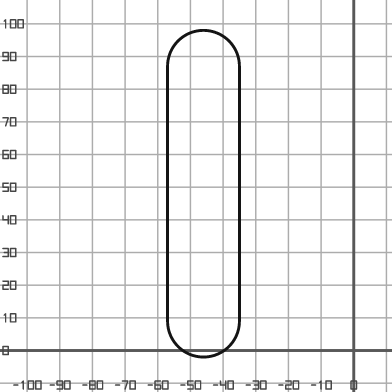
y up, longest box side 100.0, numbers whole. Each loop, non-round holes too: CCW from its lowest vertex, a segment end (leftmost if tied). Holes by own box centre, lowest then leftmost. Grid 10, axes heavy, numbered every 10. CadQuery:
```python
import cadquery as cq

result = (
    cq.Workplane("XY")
    .moveTo(-57.0, 9.0)
    .threePointArc((-46.0, -2.0), (-35.0, 9.0))
    .lineTo(-35.0, 87.0)
    .threePointArc((-46.0, 98.0), (-57.0, 87.0))
    .close()
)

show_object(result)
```